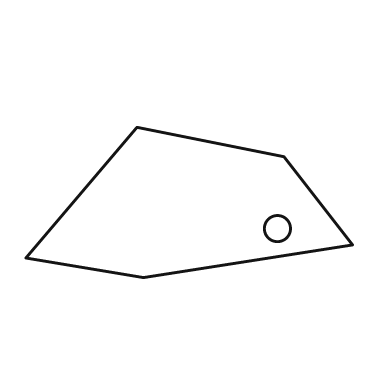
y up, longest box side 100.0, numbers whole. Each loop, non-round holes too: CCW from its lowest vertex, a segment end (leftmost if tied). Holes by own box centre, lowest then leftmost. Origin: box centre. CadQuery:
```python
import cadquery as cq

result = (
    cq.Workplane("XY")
    .moveTo(-14.0, -23.0)
    .lineTo(50.0, -13.0)
    .lineTo(29.0, 14.0)
    .lineTo(-16.0, 23.0)
    .lineTo(-50.0, -17.0)
    .close()
    .moveTo(27.0, -8.0)
    .circle(4.0)
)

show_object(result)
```